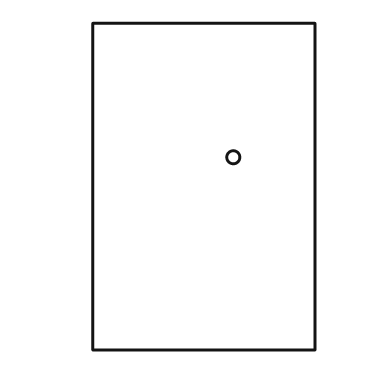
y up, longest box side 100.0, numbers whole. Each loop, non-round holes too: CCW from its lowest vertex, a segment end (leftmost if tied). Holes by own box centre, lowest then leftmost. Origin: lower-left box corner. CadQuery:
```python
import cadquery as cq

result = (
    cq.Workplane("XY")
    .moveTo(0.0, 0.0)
    .lineTo(68.0, 0.0)
    .lineTo(68.0, 100.0)
    .lineTo(0.0, 100.0)
    .close()
    .moveTo(43.0, 59.0)
    .circle(2.0)
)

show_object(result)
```